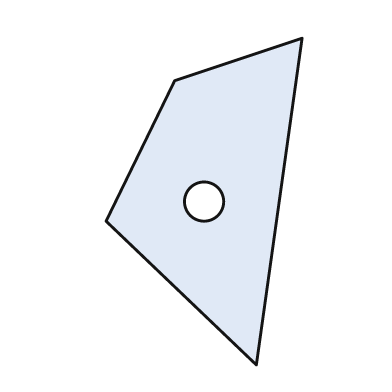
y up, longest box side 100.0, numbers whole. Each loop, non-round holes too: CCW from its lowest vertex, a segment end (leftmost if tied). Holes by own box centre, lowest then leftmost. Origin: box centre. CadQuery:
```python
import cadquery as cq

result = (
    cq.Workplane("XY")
    .moveTo(16.0, -50.0)
    .lineTo(30.0, 50.0)
    .lineTo(-9.0, 37.0)
    .lineTo(-30.0, -6.0)
    .close()
    .moveTo(0.0, 0.0)
    .circle(6.0)
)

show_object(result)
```